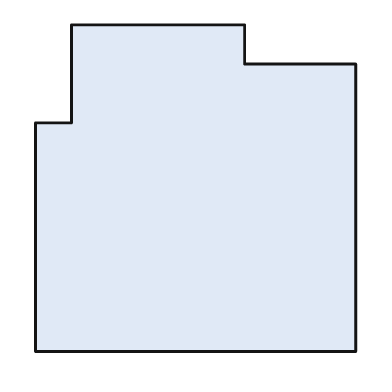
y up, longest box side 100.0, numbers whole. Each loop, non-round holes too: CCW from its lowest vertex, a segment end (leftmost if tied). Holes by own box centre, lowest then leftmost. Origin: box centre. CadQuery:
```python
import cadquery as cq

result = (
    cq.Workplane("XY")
    .moveTo(-49.0, -50.0)
    .lineTo(49.0, -50.0)
    .lineTo(49.0, 38.0)
    .lineTo(15.0, 38.0)
    .lineTo(15.0, 50.0)
    .lineTo(-38.0, 50.0)
    .lineTo(-38.0, 20.0)
    .lineTo(-49.0, 20.0)
    .close()
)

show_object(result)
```